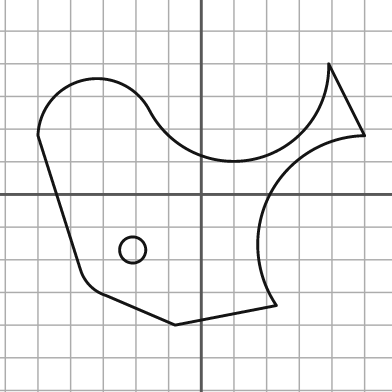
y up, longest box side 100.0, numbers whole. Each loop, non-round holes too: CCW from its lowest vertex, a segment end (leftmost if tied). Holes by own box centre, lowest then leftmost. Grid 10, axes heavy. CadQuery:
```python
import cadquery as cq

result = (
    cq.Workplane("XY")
    .moveTo(-8.0, -40.0)
    .lineTo(23.0, -34.0)
    .threePointArc((21.0, 0.0), (50.0, 18.0))
    .lineTo(39.0, 40.0)
    .threePointArc((17.0, 11.0), (-16.0, 26.0))
    .threePointArc((-36.0, 35.0), (-50.0, 18.0))
    .lineTo(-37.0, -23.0)
    .threePointArc((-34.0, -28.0), (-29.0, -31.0))
    .close()
    .moveTo(-21.0, -17.0)
    .circle(4.0)
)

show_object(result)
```